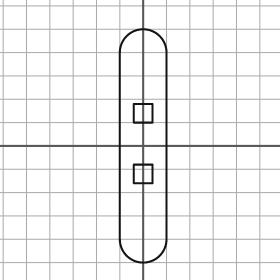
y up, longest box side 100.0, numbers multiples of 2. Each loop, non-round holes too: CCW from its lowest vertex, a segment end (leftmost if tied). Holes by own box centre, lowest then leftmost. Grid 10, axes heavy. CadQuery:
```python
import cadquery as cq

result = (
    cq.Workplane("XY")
    .moveTo(-10.0, -40.0)
    .threePointArc((0.0, -50.0), (10.0, -40.0))
    .lineTo(10.0, 40.0)
    .threePointArc((0.0, 50.0), (-10.0, 40.0))
    .close()
    .moveTo(-4.0, -16.0)
    .lineTo(4.0, -16.0)
    .lineTo(4.0, -8.0)
    .lineTo(-4.0, -8.0)
    .close()
    .moveTo(-4.0, 10.0)
    .lineTo(4.0, 10.0)
    .lineTo(4.0, 18.0)
    .lineTo(-4.0, 18.0)
    .close()
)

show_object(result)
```